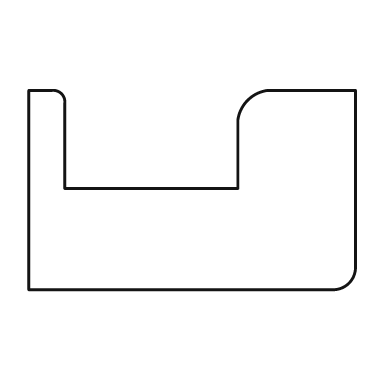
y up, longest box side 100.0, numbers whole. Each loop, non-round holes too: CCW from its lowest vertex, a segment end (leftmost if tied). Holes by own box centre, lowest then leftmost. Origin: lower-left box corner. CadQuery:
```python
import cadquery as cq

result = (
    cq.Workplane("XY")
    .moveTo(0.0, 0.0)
    .lineTo(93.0, 0.0)
    .threePointArc((98.0, 2.0), (100.0, 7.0))
    .lineTo(100.0, 61.0)
    .lineTo(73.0, 61.0)
    .threePointArc((67.0, 58.0), (64.0, 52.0))
    .lineTo(64.0, 31.0)
    .lineTo(11.0, 31.0)
    .lineTo(11.0, 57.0)
    .threePointArc((10.0, 60.0), (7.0, 61.0))
    .lineTo(0.0, 61.0)
    .close()
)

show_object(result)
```